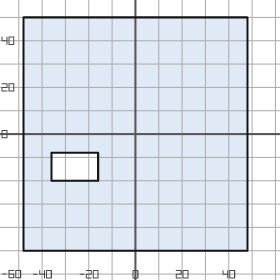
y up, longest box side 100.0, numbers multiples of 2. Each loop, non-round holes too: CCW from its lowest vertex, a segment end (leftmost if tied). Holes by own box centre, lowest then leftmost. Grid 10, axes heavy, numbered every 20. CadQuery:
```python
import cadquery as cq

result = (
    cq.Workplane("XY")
    .moveTo(-48.0, -50.0)
    .lineTo(48.0, -50.0)
    .lineTo(48.0, 50.0)
    .lineTo(-48.0, 50.0)
    .close()
    .moveTo(-36.0, -20.0)
    .lineTo(-16.0, -20.0)
    .lineTo(-16.0, -8.0)
    .lineTo(-36.0, -8.0)
    .close()
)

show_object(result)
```